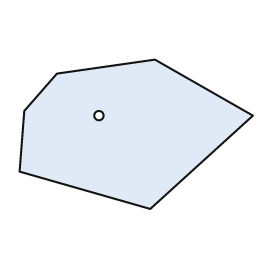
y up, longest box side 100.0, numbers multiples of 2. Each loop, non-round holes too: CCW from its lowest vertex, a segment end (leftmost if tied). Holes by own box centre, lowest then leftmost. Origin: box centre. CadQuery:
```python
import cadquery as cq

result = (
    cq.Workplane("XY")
    .moveTo(6.0, -32.0)
    .lineTo(50.0, 8.0)
    .lineTo(8.0, 32.0)
    .lineTo(-34.0, 26.0)
    .lineTo(-48.0, 10.0)
    .lineTo(-50.0, -16.0)
    .close()
    .moveTo(-16.0, 8.0)
    .circle(2.0)
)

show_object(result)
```